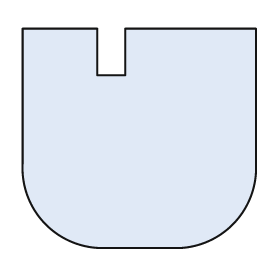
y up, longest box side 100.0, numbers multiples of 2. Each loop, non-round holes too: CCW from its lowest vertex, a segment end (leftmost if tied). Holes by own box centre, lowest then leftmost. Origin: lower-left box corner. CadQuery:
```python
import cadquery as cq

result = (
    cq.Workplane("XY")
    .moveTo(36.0, 0.0)
    .lineTo(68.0, 0.0)
    .threePointArc((90.0, 10.0), (100.0, 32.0))
    .lineTo(100.0, 94.0)
    .lineTo(44.0, 94.0)
    .lineTo(44.0, 74.0)
    .lineTo(32.0, 74.0)
    .lineTo(32.0, 94.0)
    .lineTo(0.0, 94.0)
    .lineTo(0.0, 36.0)
    .threePointArc((10.0, 10.0), (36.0, 0.0))
    .close()
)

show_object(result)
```